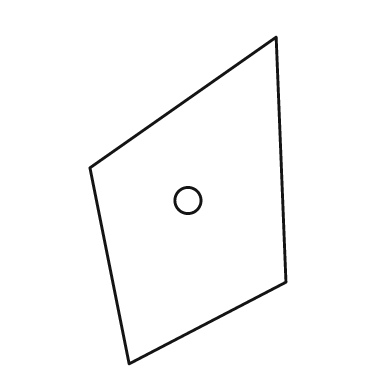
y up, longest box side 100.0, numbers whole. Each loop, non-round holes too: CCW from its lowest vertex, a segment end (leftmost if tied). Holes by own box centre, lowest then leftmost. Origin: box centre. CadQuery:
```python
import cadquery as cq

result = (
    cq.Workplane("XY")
    .moveTo(-18.0, -50.0)
    .lineTo(30.0, -25.0)
    .lineTo(27.0, 50.0)
    .lineTo(-30.0, 10.0)
    .close()
    .moveTo(0.0, 0.0)
    .circle(4.0)
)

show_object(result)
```